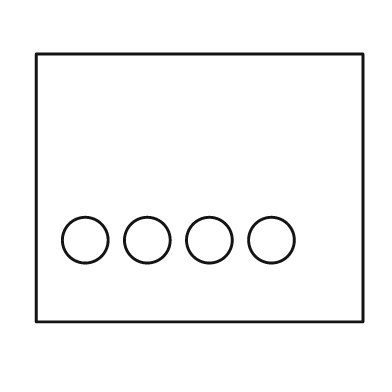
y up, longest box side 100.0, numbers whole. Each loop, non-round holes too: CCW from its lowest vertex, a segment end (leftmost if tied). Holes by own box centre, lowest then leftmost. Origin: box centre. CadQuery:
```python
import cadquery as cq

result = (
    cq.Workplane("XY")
    .moveTo(-50.0, -41.0)
    .lineTo(50.0, -41.0)
    .lineTo(50.0, 41.0)
    .lineTo(-50.0, 41.0)
    .close()
    .moveTo(-35.0, -16.0)
    .circle(7.0)
    .moveTo(-16.0, -16.0)
    .circle(7.0)
    .moveTo(3.0, -16.0)
    .circle(7.0)
    .moveTo(22.0, -16.0)
    .circle(7.0)
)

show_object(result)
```